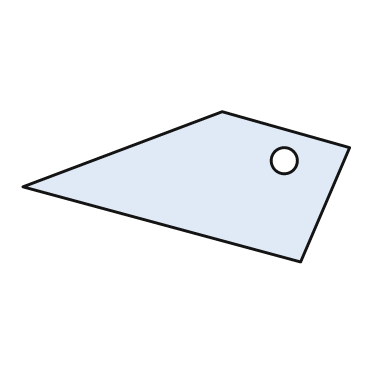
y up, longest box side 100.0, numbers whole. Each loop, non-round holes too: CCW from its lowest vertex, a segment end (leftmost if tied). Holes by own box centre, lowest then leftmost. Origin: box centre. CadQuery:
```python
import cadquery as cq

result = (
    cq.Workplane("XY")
    .moveTo(35.0, -23.0)
    .lineTo(50.0, 12.0)
    .lineTo(11.0, 23.0)
    .lineTo(-50.0, 0.0)
    .close()
    .moveTo(30.0, 8.0)
    .circle(4.0)
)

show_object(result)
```